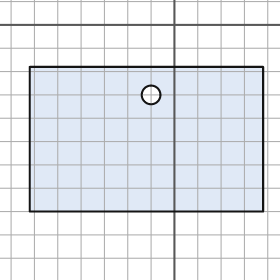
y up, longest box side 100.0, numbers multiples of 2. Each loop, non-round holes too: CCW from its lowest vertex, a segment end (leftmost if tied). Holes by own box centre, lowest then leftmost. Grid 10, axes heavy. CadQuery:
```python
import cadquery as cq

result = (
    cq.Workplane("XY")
    .moveTo(-62.0, -80.0)
    .lineTo(38.0, -80.0)
    .lineTo(38.0, -18.0)
    .lineTo(-62.0, -18.0)
    .close()
    .moveTo(-10.0, -30.0)
    .circle(4.0)
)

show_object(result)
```